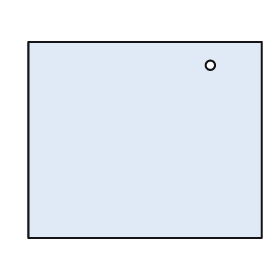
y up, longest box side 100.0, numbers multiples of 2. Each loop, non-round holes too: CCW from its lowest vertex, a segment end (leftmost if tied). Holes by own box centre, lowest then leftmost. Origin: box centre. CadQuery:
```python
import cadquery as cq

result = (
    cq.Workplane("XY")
    .moveTo(-50.0, -42.0)
    .lineTo(50.0, -42.0)
    .lineTo(50.0, 42.0)
    .lineTo(-50.0, 42.0)
    .close()
    .moveTo(28.0, 32.0)
    .circle(2.0)
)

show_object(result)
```